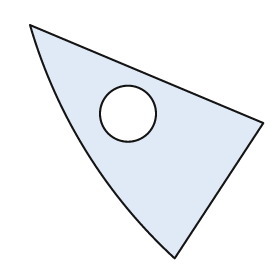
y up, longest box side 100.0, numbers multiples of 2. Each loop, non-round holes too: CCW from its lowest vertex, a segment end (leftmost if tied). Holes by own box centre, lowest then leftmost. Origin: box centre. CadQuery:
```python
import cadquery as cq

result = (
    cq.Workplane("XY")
    .moveTo(12.0, -50.0)
    .lineTo(50.0, 8.0)
    .lineTo(-50.0, 50.0)
    .threePointArc((-26.0, -4.0), (12.0, -50.0))
    .close()
    .moveTo(-8.0, 12.0)
    .circle(12.0)
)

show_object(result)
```